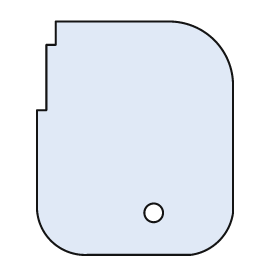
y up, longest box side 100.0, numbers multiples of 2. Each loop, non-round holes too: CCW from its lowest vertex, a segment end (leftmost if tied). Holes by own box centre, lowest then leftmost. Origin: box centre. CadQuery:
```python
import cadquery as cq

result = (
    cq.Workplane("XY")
    .moveTo(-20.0, -50.0)
    .lineTo(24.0, -50.0)
    .threePointArc((36.0, -44.0), (42.0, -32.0))
    .lineTo(42.0, 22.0)
    .threePointArc((34.0, 42.0), (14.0, 50.0))
    .lineTo(-34.0, 50.0)
    .lineTo(-34.0, 40.0)
    .lineTo(-38.0, 40.0)
    .lineTo(-38.0, 12.0)
    .lineTo(-42.0, 12.0)
    .lineTo(-42.0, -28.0)
    .threePointArc((-36.0, -44.0), (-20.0, -50.0))
    .close()
    .moveTo(8.0, -32.0)
    .circle(4.0)
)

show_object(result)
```